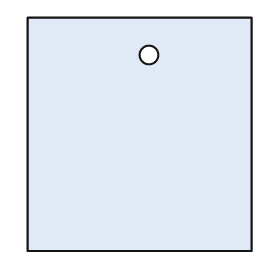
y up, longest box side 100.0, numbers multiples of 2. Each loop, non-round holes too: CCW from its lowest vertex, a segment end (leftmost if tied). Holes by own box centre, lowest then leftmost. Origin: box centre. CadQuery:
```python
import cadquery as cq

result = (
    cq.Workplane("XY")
    .moveTo(-48.0, -50.0)
    .lineTo(48.0, -50.0)
    .lineTo(48.0, 50.0)
    .lineTo(-48.0, 50.0)
    .close()
    .moveTo(4.0, 34.0)
    .circle(4.0)
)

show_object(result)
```